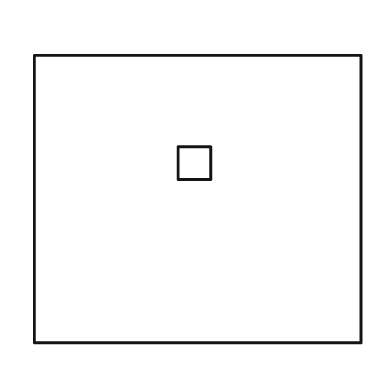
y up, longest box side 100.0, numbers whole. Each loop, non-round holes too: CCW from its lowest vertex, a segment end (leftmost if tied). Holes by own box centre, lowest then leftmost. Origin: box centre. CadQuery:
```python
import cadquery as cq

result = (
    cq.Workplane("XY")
    .moveTo(-50.0, -44.0)
    .lineTo(50.0, -44.0)
    .lineTo(50.0, 44.0)
    .lineTo(-50.0, 44.0)
    .close()
    .moveTo(-6.0, 6.0)
    .lineTo(4.0, 6.0)
    .lineTo(4.0, 16.0)
    .lineTo(-6.0, 16.0)
    .close()
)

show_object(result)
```